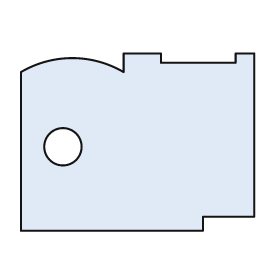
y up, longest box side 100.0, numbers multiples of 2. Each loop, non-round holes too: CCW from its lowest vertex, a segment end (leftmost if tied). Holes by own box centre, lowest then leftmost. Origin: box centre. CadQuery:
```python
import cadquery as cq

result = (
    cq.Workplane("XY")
    .moveTo(-50.0, -38.0)
    .lineTo(28.0, -38.0)
    .lineTo(28.0, -32.0)
    .lineTo(50.0, -32.0)
    .lineTo(50.0, 38.0)
    .lineTo(42.0, 38.0)
    .lineTo(42.0, 34.0)
    .lineTo(10.0, 34.0)
    .lineTo(10.0, 38.0)
    .lineTo(-6.0, 38.0)
    .lineTo(-6.0, 30.0)
    .threePointArc((-28.0, 36.0), (-50.0, 30.0))
    .close()
    .moveTo(-32.0, -2.0)
    .circle(8.0)
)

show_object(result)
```